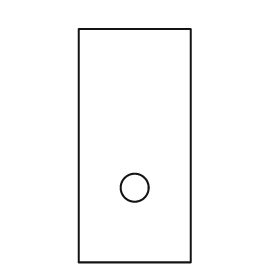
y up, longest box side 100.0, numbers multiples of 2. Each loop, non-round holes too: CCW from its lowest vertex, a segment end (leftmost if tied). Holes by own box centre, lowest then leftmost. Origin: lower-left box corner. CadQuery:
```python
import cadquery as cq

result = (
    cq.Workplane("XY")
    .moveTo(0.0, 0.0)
    .lineTo(48.0, 0.0)
    .lineTo(48.0, 100.0)
    .lineTo(0.0, 100.0)
    .close()
    .moveTo(24.0, 32.0)
    .circle(6.0)
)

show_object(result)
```